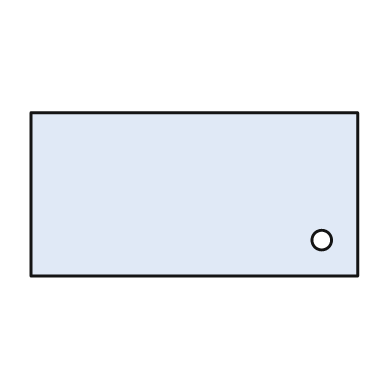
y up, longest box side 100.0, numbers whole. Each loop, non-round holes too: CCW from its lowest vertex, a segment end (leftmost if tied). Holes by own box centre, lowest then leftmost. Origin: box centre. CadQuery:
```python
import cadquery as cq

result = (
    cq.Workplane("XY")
    .moveTo(-50.0, -25.0)
    .lineTo(50.0, -25.0)
    .lineTo(50.0, 25.0)
    .lineTo(-50.0, 25.0)
    .close()
    .moveTo(39.0, -14.0)
    .circle(3.0)
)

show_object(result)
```